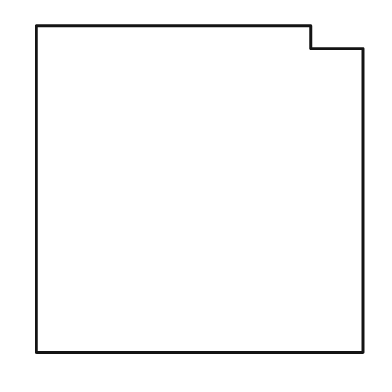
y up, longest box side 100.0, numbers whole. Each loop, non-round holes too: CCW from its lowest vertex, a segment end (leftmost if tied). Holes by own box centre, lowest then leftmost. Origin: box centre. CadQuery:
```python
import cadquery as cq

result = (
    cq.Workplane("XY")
    .moveTo(-50.0, -50.0)
    .lineTo(50.0, -50.0)
    .lineTo(50.0, 43.0)
    .lineTo(34.0, 43.0)
    .lineTo(34.0, 50.0)
    .lineTo(-50.0, 50.0)
    .close()
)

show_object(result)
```